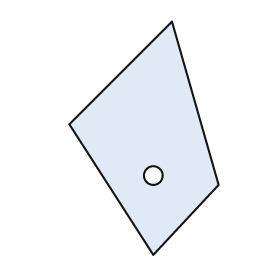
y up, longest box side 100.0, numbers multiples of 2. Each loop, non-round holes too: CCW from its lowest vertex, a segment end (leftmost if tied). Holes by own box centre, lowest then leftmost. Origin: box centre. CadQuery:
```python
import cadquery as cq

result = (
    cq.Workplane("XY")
    .moveTo(4.0, -50.0)
    .lineTo(32.0, -20.0)
    .lineTo(12.0, 50.0)
    .lineTo(-32.0, 6.0)
    .close()
    .moveTo(4.0, -16.0)
    .circle(4.0)
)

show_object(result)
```